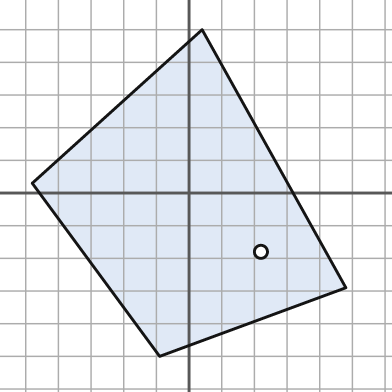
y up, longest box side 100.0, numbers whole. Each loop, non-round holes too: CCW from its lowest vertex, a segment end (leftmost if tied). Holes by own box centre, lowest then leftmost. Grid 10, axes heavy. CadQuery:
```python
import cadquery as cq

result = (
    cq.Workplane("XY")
    .moveTo(-9.0, -50.0)
    .lineTo(48.0, -29.0)
    .lineTo(4.0, 50.0)
    .lineTo(-48.0, 3.0)
    .close()
    .moveTo(22.0, -18.0)
    .circle(2.0)
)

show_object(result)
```